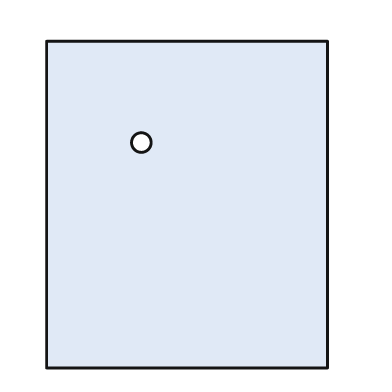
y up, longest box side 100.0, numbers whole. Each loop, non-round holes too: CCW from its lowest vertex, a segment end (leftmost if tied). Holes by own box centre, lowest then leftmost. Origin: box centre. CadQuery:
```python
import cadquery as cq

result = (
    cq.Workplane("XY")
    .moveTo(-43.0, -50.0)
    .lineTo(43.0, -50.0)
    .lineTo(43.0, 50.0)
    .lineTo(-43.0, 50.0)
    .close()
    .moveTo(-14.0, 19.0)
    .circle(3.0)
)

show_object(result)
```